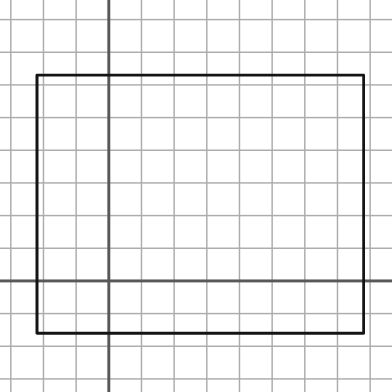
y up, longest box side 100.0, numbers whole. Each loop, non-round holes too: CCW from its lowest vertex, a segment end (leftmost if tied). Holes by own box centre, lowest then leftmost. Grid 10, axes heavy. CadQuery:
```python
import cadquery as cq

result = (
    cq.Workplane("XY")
    .moveTo(-22.0, -16.0)
    .lineTo(78.0, -16.0)
    .lineTo(78.0, 63.0)
    .lineTo(-22.0, 63.0)
    .close()
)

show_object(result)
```